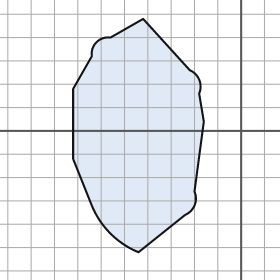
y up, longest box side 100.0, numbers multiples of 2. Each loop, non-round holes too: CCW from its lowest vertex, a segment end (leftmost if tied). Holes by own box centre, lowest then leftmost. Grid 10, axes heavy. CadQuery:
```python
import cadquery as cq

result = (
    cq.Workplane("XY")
    .moveTo(-44.0, -52.0)
    .lineTo(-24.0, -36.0)
    .threePointArc((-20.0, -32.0), (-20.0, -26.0))
    .lineTo(-16.0, 4.0)
    .lineTo(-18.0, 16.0)
    .threePointArc((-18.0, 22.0), (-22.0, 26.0))
    .lineTo(-42.0, 48.0)
    .lineTo(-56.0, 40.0)
    .threePointArc((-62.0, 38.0), (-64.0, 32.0))
    .lineTo(-72.0, 18.0)
    .lineTo(-72.0, -12.0)
    .lineTo(-64.0, -32.0)
    .threePointArc((-56.0, -44.0), (-44.0, -52.0))
    .close()
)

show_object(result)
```